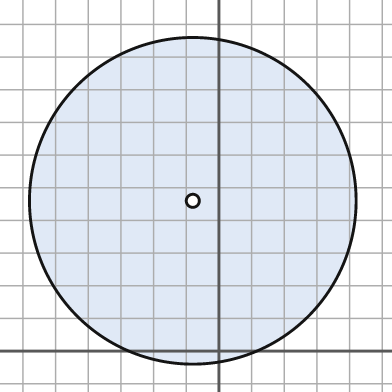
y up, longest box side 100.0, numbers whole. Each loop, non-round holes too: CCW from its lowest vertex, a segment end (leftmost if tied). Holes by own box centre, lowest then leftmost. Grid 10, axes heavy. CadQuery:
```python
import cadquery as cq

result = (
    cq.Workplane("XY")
    .moveTo(-8.0, 46.0)
    .circle(50.0)
    .moveTo(-8.0, 46.0)
    .circle(2.0)
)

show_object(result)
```